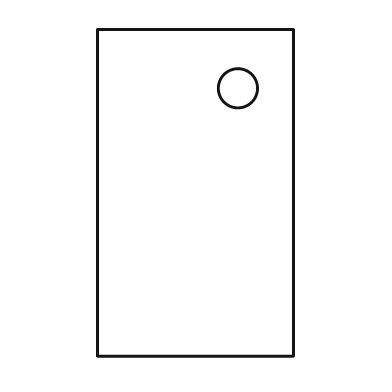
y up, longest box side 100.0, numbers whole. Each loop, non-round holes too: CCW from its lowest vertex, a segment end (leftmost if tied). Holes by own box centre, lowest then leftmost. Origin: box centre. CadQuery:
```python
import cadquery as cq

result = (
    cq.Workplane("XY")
    .moveTo(-30.0, -50.0)
    .lineTo(30.0, -50.0)
    .lineTo(30.0, 50.0)
    .lineTo(-30.0, 50.0)
    .close()
    .moveTo(13.0, 32.0)
    .circle(6.0)
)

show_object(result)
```